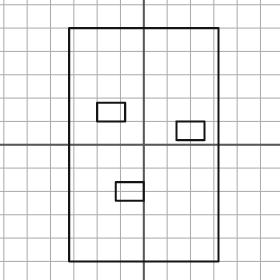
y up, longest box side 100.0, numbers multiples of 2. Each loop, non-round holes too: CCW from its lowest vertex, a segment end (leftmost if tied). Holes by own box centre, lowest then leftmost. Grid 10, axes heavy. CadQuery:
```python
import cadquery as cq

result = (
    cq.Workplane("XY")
    .moveTo(-32.0, -50.0)
    .lineTo(32.0, -50.0)
    .lineTo(32.0, 50.0)
    .lineTo(-32.0, 50.0)
    .close()
    .moveTo(-12.0, -24.0)
    .lineTo(0.0, -24.0)
    .lineTo(0.0, -16.0)
    .lineTo(-12.0, -16.0)
    .close()
    .moveTo(14.0, 2.0)
    .lineTo(26.0, 2.0)
    .lineTo(26.0, 10.0)
    .lineTo(14.0, 10.0)
    .close()
    .moveTo(-20.0, 10.0)
    .lineTo(-8.0, 10.0)
    .lineTo(-8.0, 18.0)
    .lineTo(-20.0, 18.0)
    .close()
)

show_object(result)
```